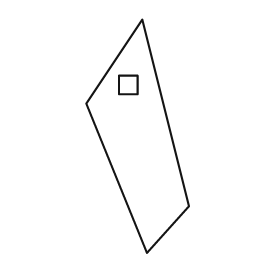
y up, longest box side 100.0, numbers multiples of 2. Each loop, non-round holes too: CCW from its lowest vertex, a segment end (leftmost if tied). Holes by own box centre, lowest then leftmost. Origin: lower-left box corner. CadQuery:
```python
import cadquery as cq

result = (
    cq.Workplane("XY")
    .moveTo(26.0, 0.0)
    .lineTo(44.0, 20.0)
    .lineTo(24.0, 100.0)
    .lineTo(0.0, 64.0)
    .close()
    .moveTo(14.0, 68.0)
    .lineTo(22.0, 68.0)
    .lineTo(22.0, 76.0)
    .lineTo(14.0, 76.0)
    .close()
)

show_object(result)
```